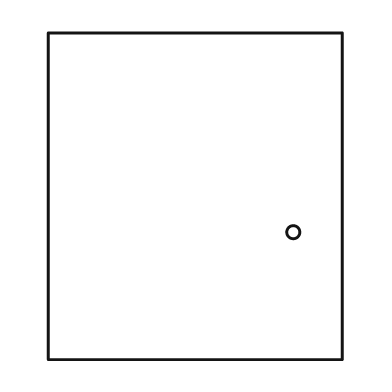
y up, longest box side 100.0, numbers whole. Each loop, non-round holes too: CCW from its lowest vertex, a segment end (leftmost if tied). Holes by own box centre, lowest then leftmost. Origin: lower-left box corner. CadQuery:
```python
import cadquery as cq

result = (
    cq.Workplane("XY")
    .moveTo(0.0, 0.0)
    .lineTo(90.0, 0.0)
    .lineTo(90.0, 100.0)
    .lineTo(0.0, 100.0)
    .close()
    .moveTo(75.0, 39.0)
    .circle(2.0)
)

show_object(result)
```